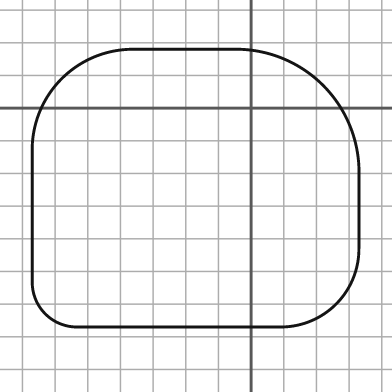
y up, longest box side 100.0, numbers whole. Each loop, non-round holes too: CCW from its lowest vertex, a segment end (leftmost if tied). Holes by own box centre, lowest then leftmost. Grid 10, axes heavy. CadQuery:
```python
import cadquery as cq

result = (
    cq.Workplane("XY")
    .moveTo(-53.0, -67.0)
    .lineTo(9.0, -67.0)
    .threePointArc((26.0, -60.0), (33.0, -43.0))
    .lineTo(33.0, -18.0)
    .threePointArc((22.0, 7.0), (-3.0, 18.0))
    .lineTo(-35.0, 18.0)
    .threePointArc((-58.0, 9.0), (-67.0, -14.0))
    .lineTo(-67.0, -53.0)
    .threePointArc((-63.0, -63.0), (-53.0, -67.0))
    .close()
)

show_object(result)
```